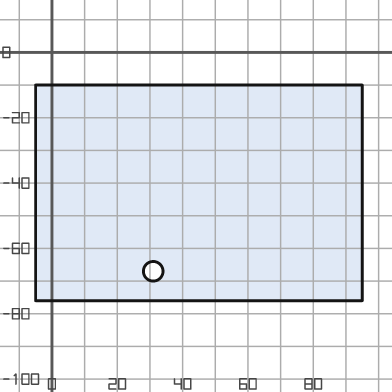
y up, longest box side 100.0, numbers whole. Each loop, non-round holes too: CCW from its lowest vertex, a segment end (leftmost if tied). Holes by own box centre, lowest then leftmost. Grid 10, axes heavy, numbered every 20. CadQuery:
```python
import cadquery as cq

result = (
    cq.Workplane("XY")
    .moveTo(-5.0, -76.0)
    .lineTo(95.0, -76.0)
    .lineTo(95.0, -10.0)
    .lineTo(-5.0, -10.0)
    .close()
    .moveTo(31.0, -67.0)
    .circle(3.0)
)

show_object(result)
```